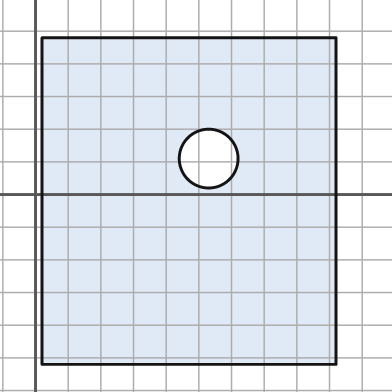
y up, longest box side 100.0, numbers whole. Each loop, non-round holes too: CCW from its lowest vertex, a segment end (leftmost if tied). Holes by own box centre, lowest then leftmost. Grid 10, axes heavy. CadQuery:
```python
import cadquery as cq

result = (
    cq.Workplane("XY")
    .moveTo(2.0, -52.0)
    .lineTo(92.0, -52.0)
    .lineTo(92.0, 48.0)
    .lineTo(2.0, 48.0)
    .close()
    .moveTo(53.0, 11.0)
    .circle(9.0)
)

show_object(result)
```